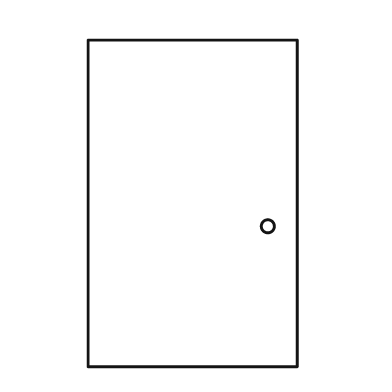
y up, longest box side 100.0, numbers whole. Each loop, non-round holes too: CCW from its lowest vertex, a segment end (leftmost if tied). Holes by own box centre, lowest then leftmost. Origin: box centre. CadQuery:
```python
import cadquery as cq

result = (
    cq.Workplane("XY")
    .moveTo(-32.0, -50.0)
    .lineTo(32.0, -50.0)
    .lineTo(32.0, 50.0)
    .lineTo(-32.0, 50.0)
    .close()
    .moveTo(23.0, -7.0)
    .circle(2.0)
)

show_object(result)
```